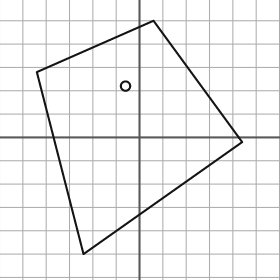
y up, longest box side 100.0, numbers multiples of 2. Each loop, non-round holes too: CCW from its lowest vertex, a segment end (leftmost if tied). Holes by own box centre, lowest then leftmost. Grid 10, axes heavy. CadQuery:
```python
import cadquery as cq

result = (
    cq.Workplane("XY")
    .moveTo(-24.0, -50.0)
    .lineTo(44.0, -2.0)
    .lineTo(6.0, 50.0)
    .lineTo(-44.0, 28.0)
    .close()
    .moveTo(-6.0, 22.0)
    .circle(2.0)
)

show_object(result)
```